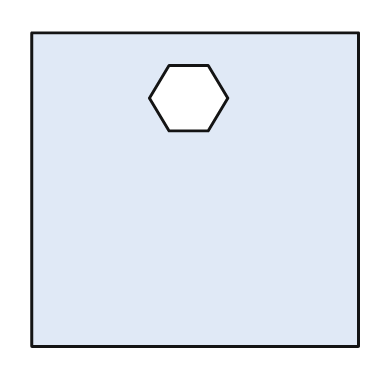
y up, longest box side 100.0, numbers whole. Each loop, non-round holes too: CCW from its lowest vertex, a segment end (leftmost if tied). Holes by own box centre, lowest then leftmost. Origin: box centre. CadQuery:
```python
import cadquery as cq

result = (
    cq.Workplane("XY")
    .moveTo(-50.0, -48.0)
    .lineTo(50.0, -48.0)
    .lineTo(50.0, 48.0)
    .lineTo(-50.0, 48.0)
    .close()
    .moveTo(-8.0, 18.0)
    .lineTo(4.0, 18.0)
    .lineTo(10.0, 28.0)
    .lineTo(4.0, 38.0)
    .lineTo(-8.0, 38.0)
    .lineTo(-14.0, 28.0)
    .close()
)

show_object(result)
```